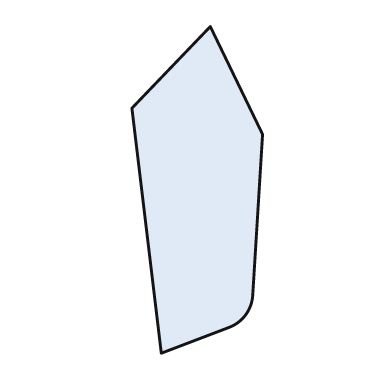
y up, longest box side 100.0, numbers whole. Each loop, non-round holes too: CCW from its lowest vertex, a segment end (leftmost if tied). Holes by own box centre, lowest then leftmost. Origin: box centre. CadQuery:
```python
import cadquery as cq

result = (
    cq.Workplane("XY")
    .moveTo(-11.0, -50.0)
    .lineTo(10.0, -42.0)
    .threePointArc((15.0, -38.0), (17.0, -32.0))
    .lineTo(20.0, 17.0)
    .lineTo(4.0, 50.0)
    .lineTo(-20.0, 25.0)
    .close()
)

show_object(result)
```